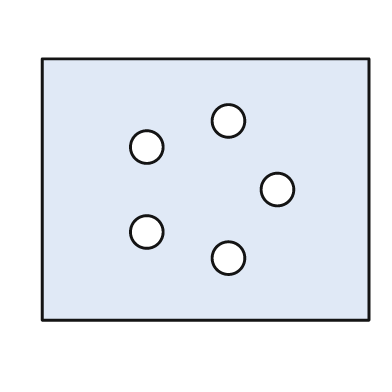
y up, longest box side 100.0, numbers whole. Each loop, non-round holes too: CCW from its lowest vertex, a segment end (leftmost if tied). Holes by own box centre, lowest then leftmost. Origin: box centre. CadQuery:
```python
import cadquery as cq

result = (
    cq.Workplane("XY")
    .moveTo(-50.0, -40.0)
    .lineTo(50.0, -40.0)
    .lineTo(50.0, 40.0)
    .lineTo(-50.0, 40.0)
    .close()
    .moveTo(7.0, -21.0)
    .circle(5.0)
    .moveTo(-18.0, -13.0)
    .circle(5.0)
    .moveTo(22.0, 0.0)
    .circle(5.0)
    .moveTo(-18.0, 13.0)
    .circle(5.0)
    .moveTo(7.0, 21.0)
    .circle(5.0)
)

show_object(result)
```